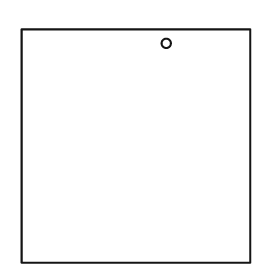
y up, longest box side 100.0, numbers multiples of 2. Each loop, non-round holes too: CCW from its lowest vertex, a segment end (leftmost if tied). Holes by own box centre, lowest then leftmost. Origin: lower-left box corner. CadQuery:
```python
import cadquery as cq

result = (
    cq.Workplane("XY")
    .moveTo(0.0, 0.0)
    .lineTo(98.0, 0.0)
    .lineTo(98.0, 100.0)
    .lineTo(0.0, 100.0)
    .close()
    .moveTo(62.0, 94.0)
    .circle(2.0)
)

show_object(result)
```